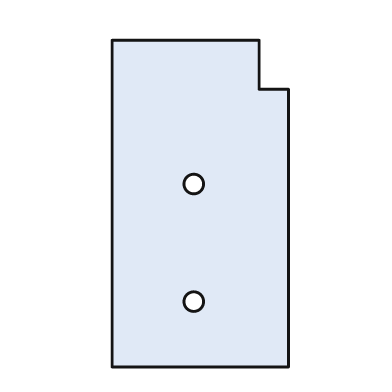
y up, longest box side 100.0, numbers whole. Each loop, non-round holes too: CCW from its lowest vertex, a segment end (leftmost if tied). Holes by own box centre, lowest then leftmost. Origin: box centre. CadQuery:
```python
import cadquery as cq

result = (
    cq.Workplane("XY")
    .moveTo(-27.0, -50.0)
    .lineTo(27.0, -50.0)
    .lineTo(27.0, 35.0)
    .lineTo(18.0, 35.0)
    .lineTo(18.0, 50.0)
    .lineTo(-27.0, 50.0)
    .close()
    .moveTo(-2.0, -30.0)
    .circle(3.0)
    .moveTo(-2.0, 6.0)
    .circle(3.0)
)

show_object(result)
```